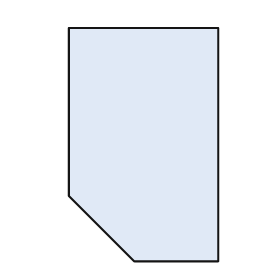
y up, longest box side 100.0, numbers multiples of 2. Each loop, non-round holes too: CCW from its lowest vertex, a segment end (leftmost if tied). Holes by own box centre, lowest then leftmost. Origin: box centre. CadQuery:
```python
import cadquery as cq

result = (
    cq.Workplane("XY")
    .moveTo(-4.0, -50.0)
    .lineTo(32.0, -50.0)
    .lineTo(32.0, 50.0)
    .lineTo(-32.0, 50.0)
    .lineTo(-32.0, -22.0)
    .close()
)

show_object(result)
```